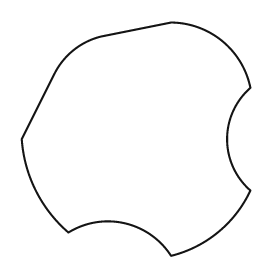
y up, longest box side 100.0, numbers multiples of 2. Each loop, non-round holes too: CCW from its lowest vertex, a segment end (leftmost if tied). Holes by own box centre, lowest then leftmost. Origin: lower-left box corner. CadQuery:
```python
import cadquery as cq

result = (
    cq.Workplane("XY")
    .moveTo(64.0, 0.0)
    .threePointArc((84.0, 10.0), (98.0, 28.0))
    .threePointArc((88.0, 50.0), (98.0, 72.0))
    .threePointArc((86.0, 92.0), (64.0, 100.0))
    .lineTo(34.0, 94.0)
    .threePointArc((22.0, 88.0), (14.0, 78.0))
    .lineTo(0.0, 50.0)
    .threePointArc((6.0, 28.0), (20.0, 10.0))
    .threePointArc((44.0, 14.0), (64.0, 0.0))
    .close()
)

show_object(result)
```